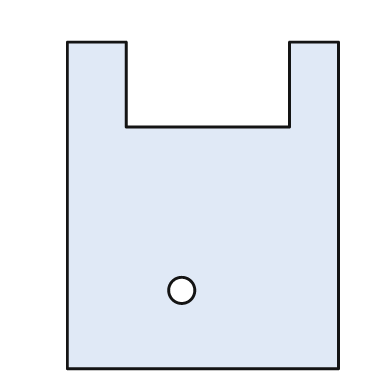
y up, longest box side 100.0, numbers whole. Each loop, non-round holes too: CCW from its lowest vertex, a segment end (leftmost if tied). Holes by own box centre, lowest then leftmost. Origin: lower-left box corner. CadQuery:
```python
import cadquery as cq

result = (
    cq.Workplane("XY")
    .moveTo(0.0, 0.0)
    .lineTo(83.0, 0.0)
    .lineTo(83.0, 100.0)
    .lineTo(68.0, 100.0)
    .lineTo(68.0, 74.0)
    .lineTo(18.0, 74.0)
    .lineTo(18.0, 100.0)
    .lineTo(0.0, 100.0)
    .close()
    .moveTo(35.0, 24.0)
    .circle(4.0)
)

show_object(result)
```